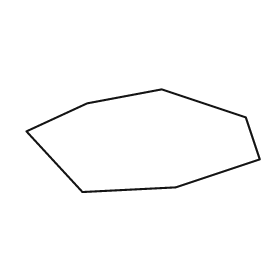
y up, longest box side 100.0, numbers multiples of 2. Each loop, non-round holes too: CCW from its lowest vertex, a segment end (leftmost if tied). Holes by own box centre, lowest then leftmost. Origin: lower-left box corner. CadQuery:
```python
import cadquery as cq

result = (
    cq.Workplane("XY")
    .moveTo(24.0, 0.0)
    .lineTo(64.0, 2.0)
    .lineTo(100.0, 14.0)
    .lineTo(94.0, 32.0)
    .lineTo(58.0, 44.0)
    .lineTo(26.0, 38.0)
    .lineTo(0.0, 26.0)
    .close()
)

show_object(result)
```